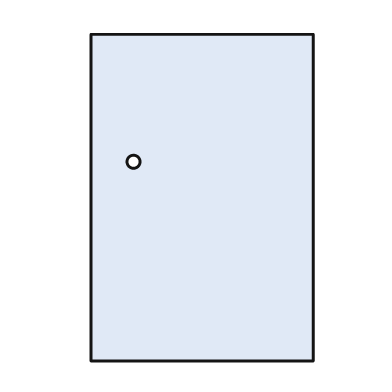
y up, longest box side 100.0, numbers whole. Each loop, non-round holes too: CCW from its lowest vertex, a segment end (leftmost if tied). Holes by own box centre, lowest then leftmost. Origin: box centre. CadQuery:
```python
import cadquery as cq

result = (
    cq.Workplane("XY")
    .moveTo(-34.0, -50.0)
    .lineTo(34.0, -50.0)
    .lineTo(34.0, 50.0)
    .lineTo(-34.0, 50.0)
    .close()
    .moveTo(-21.0, 11.0)
    .circle(2.0)
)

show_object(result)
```